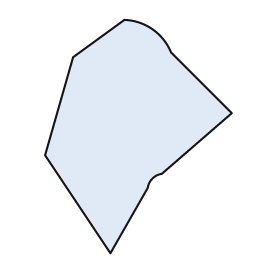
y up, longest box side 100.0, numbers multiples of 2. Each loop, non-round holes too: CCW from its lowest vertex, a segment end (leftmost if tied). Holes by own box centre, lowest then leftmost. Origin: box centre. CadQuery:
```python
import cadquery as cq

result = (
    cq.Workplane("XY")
    .moveTo(-12.0, -50.0)
    .lineTo(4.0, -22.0)
    .threePointArc((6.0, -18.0), (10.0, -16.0))
    .lineTo(40.0, 10.0)
    .lineTo(14.0, 36.0)
    .threePointArc((6.0, 46.0), (-6.0, 50.0))
    .lineTo(-28.0, 34.0)
    .lineTo(-40.0, -8.0)
    .close()
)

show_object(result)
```